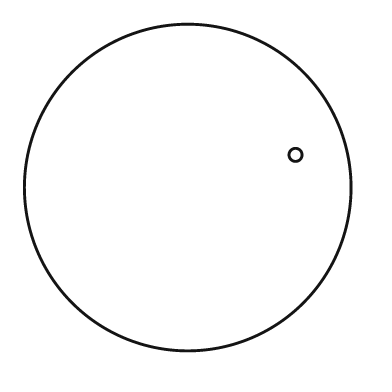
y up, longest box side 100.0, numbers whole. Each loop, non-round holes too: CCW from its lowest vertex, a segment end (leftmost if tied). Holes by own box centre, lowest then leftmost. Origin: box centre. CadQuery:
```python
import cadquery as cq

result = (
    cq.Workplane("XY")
    .moveTo(0.0, 0.0)
    .circle(50.0)
    .moveTo(33.0, 10.0)
    .circle(2.0)
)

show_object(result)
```